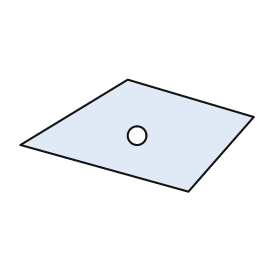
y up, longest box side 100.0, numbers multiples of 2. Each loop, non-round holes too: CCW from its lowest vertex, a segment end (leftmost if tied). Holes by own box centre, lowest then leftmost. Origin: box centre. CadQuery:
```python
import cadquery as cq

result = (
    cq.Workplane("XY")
    .moveTo(22.0, -24.0)
    .lineTo(50.0, 8.0)
    .lineTo(-4.0, 24.0)
    .lineTo(-50.0, -4.0)
    .close()
    .moveTo(0.0, 0.0)
    .circle(4.0)
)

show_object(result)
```